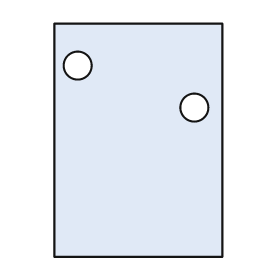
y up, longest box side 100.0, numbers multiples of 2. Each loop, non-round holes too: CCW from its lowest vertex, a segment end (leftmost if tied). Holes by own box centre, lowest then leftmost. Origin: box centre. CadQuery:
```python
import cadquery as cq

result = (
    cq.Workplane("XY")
    .moveTo(-36.0, -50.0)
    .lineTo(36.0, -50.0)
    .lineTo(36.0, 50.0)
    .lineTo(-36.0, 50.0)
    .close()
    .moveTo(24.0, 14.0)
    .circle(6.0)
    .moveTo(-26.0, 32.0)
    .circle(6.0)
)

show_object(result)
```